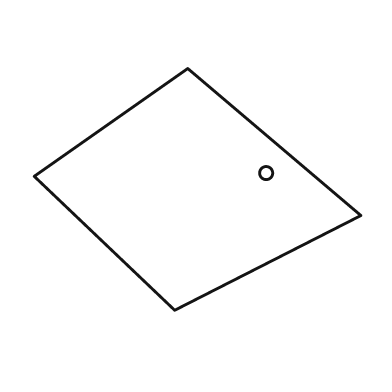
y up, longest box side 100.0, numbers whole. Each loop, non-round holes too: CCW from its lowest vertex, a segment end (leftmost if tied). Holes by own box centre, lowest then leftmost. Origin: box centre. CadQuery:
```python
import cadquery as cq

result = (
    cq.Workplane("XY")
    .moveTo(-7.0, -37.0)
    .lineTo(50.0, -8.0)
    .lineTo(-3.0, 37.0)
    .lineTo(-50.0, 4.0)
    .close()
    .moveTo(21.0, 5.0)
    .circle(2.0)
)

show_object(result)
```